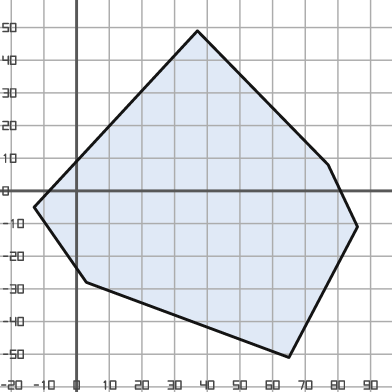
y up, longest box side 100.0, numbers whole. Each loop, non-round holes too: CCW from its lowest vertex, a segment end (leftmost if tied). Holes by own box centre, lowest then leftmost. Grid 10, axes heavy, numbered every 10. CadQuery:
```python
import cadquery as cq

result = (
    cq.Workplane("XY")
    .moveTo(65.0, -51.0)
    .lineTo(86.0, -11.0)
    .lineTo(77.0, 8.0)
    .lineTo(37.0, 49.0)
    .lineTo(-13.0, -5.0)
    .lineTo(3.0, -28.0)
    .close()
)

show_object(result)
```